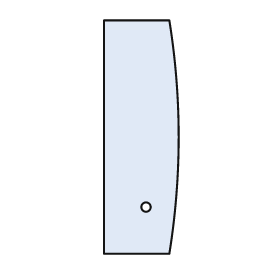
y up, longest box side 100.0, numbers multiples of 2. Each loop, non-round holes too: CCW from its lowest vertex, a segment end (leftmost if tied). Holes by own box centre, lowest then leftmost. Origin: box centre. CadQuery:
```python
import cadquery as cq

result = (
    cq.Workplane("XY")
    .moveTo(-16.0, -50.0)
    .lineTo(12.0, -50.0)
    .threePointArc((16.0, 0.0), (12.0, 50.0))
    .lineTo(-16.0, 50.0)
    .close()
    .moveTo(2.0, -30.0)
    .circle(2.0)
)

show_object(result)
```